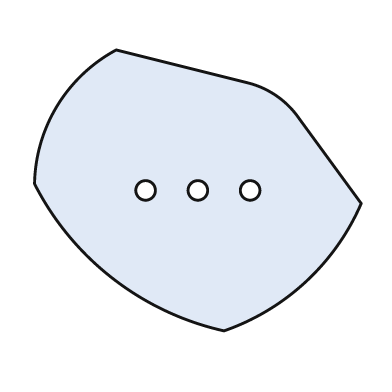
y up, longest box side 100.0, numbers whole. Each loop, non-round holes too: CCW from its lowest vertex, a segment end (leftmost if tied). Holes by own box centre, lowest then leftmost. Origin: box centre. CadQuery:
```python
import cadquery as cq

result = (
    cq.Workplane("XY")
    .moveTo(8.0, -43.0)
    .threePointArc((33.0, -28.0), (50.0, -4.0))
    .lineTo(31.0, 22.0)
    .threePointArc((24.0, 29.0), (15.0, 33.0))
    .lineTo(-25.0, 43.0)
    .threePointArc((-43.0, 26.0), (-50.0, 2.0))
    .threePointArc((-26.0, -27.0), (8.0, -43.0))
    .close()
    .moveTo(-16.0, 0.0)
    .circle(3.0)
    .moveTo(0.0, 0.0)
    .circle(3.0)
    .moveTo(16.0, 0.0)
    .circle(3.0)
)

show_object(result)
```